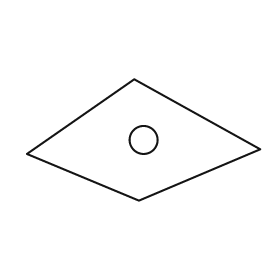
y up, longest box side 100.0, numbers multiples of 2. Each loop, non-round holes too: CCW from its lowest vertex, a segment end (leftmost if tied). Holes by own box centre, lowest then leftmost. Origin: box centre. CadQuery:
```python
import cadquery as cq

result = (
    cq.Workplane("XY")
    .moveTo(-2.0, -26.0)
    .lineTo(50.0, -4.0)
    .lineTo(-4.0, 26.0)
    .lineTo(-50.0, -6.0)
    .close()
    .moveTo(0.0, 0.0)
    .circle(6.0)
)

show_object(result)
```